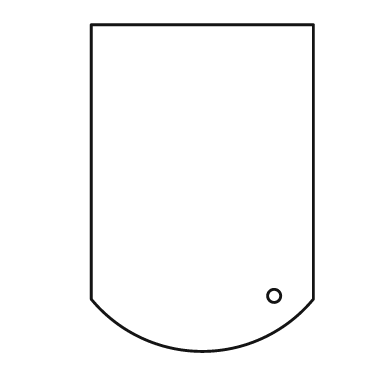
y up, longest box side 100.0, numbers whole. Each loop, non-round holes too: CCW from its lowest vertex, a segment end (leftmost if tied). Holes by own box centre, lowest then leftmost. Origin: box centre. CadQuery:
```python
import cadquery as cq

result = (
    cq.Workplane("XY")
    .moveTo(-34.0, -34.0)
    .threePointArc((0.0, -50.0), (34.0, -34.0))
    .lineTo(34.0, 50.0)
    .lineTo(-34.0, 50.0)
    .close()
    .moveTo(22.0, -33.0)
    .circle(2.0)
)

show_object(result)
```